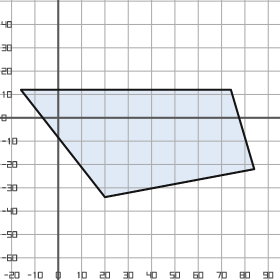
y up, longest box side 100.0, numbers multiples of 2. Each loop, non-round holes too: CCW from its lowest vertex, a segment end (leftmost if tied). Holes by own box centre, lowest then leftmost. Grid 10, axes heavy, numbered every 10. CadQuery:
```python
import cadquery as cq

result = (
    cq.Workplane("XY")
    .moveTo(20.0, -34.0)
    .lineTo(84.0, -22.0)
    .lineTo(74.0, 12.0)
    .lineTo(-16.0, 12.0)
    .close()
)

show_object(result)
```